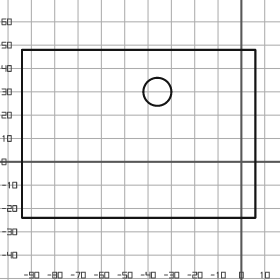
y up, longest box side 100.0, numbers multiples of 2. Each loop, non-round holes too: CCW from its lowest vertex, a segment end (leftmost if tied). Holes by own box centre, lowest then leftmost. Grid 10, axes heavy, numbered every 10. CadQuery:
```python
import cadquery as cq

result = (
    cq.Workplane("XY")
    .moveTo(-94.0, -24.0)
    .lineTo(6.0, -24.0)
    .lineTo(6.0, 48.0)
    .lineTo(-94.0, 48.0)
    .close()
    .moveTo(-36.0, 30.0)
    .circle(6.0)
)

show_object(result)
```